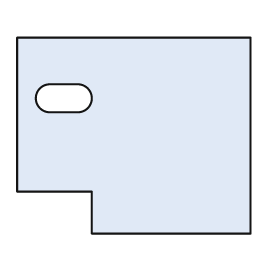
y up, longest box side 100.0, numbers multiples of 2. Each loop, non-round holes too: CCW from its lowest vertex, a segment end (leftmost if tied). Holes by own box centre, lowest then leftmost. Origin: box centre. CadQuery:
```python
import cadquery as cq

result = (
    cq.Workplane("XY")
    .moveTo(-18.0, -42.0)
    .lineTo(50.0, -42.0)
    .lineTo(50.0, 42.0)
    .lineTo(-50.0, 42.0)
    .lineTo(-50.0, -24.0)
    .lineTo(-18.0, -24.0)
    .close()
    .moveTo(-36.0, 10.0)
    .lineTo(-24.0, 10.0)
    .threePointArc((-18.0, 16.0), (-24.0, 22.0))
    .lineTo(-36.0, 22.0)
    .threePointArc((-42.0, 16.0), (-36.0, 10.0))
    .close()
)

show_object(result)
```